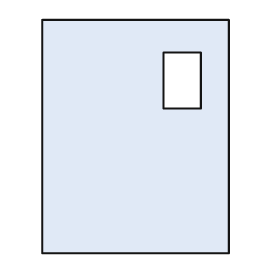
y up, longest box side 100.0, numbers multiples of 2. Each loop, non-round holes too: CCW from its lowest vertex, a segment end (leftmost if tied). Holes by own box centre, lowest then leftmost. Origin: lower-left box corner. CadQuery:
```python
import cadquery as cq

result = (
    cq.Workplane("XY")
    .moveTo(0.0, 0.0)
    .lineTo(80.0, 0.0)
    .lineTo(80.0, 100.0)
    .lineTo(0.0, 100.0)
    .close()
    .moveTo(52.0, 62.0)
    .lineTo(68.0, 62.0)
    .lineTo(68.0, 86.0)
    .lineTo(52.0, 86.0)
    .close()
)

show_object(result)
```